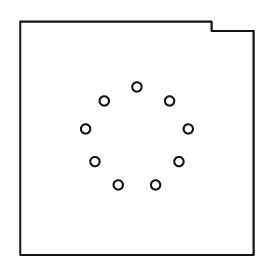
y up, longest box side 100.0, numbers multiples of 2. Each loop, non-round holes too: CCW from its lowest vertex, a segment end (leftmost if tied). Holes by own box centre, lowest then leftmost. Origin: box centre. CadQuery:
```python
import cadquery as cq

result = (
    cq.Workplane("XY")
    .moveTo(-50.0, -50.0)
    .lineTo(50.0, -50.0)
    .lineTo(50.0, 46.0)
    .lineTo(32.0, 46.0)
    .lineTo(32.0, 50.0)
    .lineTo(-50.0, 50.0)
    .close()
    .moveTo(-8.0, -20.0)
    .circle(2.0)
    .moveTo(8.0, -20.0)
    .circle(2.0)
    .moveTo(-18.0, -10.0)
    .circle(2.0)
    .moveTo(18.0, -10.0)
    .circle(2.0)
    .moveTo(-22.0, 4.0)
    .circle(2.0)
    .moveTo(22.0, 4.0)
    .circle(2.0)
    .moveTo(-14.0, 16.0)
    .circle(2.0)
    .moveTo(14.0, 16.0)
    .circle(2.0)
    .moveTo(0.0, 22.0)
    .circle(2.0)
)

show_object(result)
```